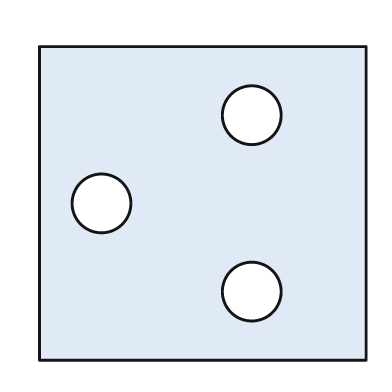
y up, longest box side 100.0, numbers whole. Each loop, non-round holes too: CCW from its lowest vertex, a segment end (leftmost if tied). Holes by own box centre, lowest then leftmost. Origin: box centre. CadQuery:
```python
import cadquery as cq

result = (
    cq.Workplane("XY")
    .moveTo(-50.0, -48.0)
    .lineTo(50.0, -48.0)
    .lineTo(50.0, 48.0)
    .lineTo(-50.0, 48.0)
    .close()
    .moveTo(15.0, -27.0)
    .circle(9.0)
    .moveTo(-31.0, 0.0)
    .circle(9.0)
    .moveTo(15.0, 27.0)
    .circle(9.0)
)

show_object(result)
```